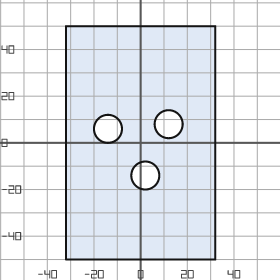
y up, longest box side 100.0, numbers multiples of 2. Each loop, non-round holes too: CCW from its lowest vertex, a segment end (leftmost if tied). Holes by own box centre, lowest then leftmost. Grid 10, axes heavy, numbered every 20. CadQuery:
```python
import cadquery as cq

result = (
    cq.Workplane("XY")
    .moveTo(-32.0, -50.0)
    .lineTo(32.0, -50.0)
    .lineTo(32.0, 50.0)
    .lineTo(-32.0, 50.0)
    .close()
    .moveTo(2.0, -14.0)
    .circle(6.0)
    .moveTo(-14.0, 6.0)
    .circle(6.0)
    .moveTo(12.0, 8.0)
    .circle(6.0)
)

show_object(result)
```